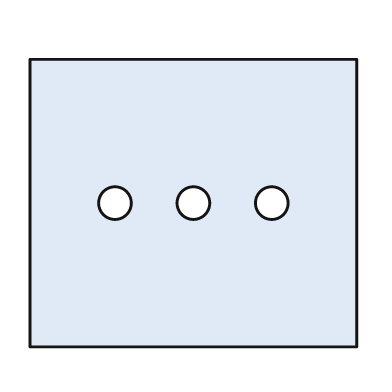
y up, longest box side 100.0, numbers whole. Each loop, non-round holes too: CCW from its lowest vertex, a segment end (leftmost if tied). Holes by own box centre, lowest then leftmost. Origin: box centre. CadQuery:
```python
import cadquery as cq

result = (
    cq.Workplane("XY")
    .moveTo(-50.0, -44.0)
    .lineTo(50.0, -44.0)
    .lineTo(50.0, 44.0)
    .lineTo(-50.0, 44.0)
    .close()
    .moveTo(-24.0, 0.0)
    .circle(5.0)
    .moveTo(0.0, 0.0)
    .circle(5.0)
    .moveTo(24.0, 0.0)
    .circle(5.0)
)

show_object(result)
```